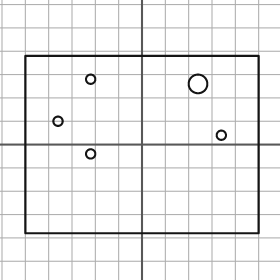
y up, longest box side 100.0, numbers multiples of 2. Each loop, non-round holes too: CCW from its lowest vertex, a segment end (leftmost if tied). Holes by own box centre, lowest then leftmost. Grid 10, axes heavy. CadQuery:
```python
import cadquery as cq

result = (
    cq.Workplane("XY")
    .moveTo(-50.0, -38.0)
    .lineTo(50.0, -38.0)
    .lineTo(50.0, 38.0)
    .lineTo(-50.0, 38.0)
    .close()
    .moveTo(-22.0, -4.0)
    .circle(2.0)
    .moveTo(34.0, 4.0)
    .circle(2.0)
    .moveTo(-36.0, 10.0)
    .circle(2.0)
    .moveTo(24.0, 26.0)
    .circle(4.0)
    .moveTo(-22.0, 28.0)
    .circle(2.0)
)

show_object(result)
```